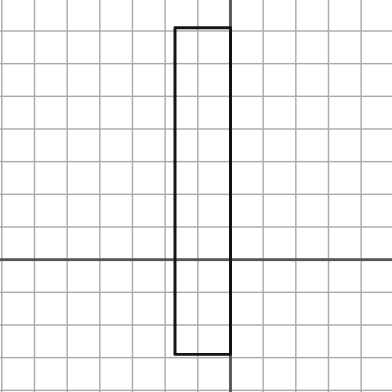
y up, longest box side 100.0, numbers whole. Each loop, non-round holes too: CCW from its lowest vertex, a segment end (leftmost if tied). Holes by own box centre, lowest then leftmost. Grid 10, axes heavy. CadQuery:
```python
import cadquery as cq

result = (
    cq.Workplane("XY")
    .moveTo(-17.0, -29.0)
    .lineTo(0.0, -29.0)
    .lineTo(0.0, 71.0)
    .lineTo(-17.0, 71.0)
    .close()
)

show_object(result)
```